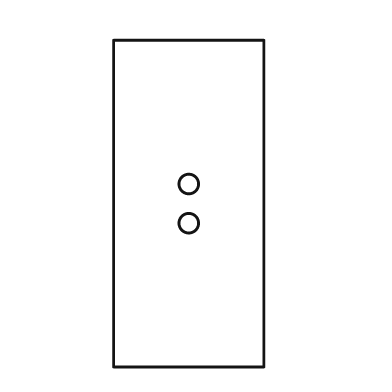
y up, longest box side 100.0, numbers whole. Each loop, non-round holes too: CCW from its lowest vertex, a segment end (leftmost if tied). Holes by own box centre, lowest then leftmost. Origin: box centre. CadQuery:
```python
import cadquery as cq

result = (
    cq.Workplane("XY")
    .moveTo(-23.0, -50.0)
    .lineTo(23.0, -50.0)
    .lineTo(23.0, 50.0)
    .lineTo(-23.0, 50.0)
    .close()
    .moveTo(0.0, -6.0)
    .circle(3.0)
    .moveTo(0.0, 6.0)
    .circle(3.0)
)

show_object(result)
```